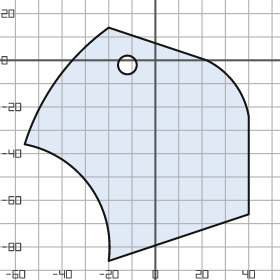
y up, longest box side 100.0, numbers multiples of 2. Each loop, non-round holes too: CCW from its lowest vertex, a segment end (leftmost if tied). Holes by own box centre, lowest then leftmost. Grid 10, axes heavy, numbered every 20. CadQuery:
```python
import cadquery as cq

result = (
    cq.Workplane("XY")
    .moveTo(-20.0, -86.0)
    .lineTo(40.0, -66.0)
    .lineTo(40.0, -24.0)
    .threePointArc((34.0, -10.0), (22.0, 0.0))
    .lineTo(-20.0, 14.0)
    .threePointArc((-42.0, -8.0), (-56.0, -36.0))
    .threePointArc((-28.0, -54.0), (-20.0, -86.0))
    .close()
    .moveTo(-12.0, -2.0)
    .circle(4.0)
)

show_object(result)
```